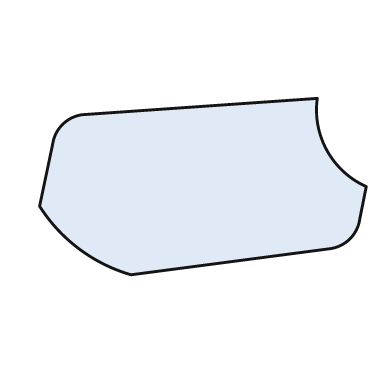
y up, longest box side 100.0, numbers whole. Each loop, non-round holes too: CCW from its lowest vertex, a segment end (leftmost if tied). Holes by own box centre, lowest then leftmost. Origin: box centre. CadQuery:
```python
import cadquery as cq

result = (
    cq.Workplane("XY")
    .moveTo(-22.0, -27.0)
    .lineTo(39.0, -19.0)
    .threePointArc((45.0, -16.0), (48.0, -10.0))
    .lineTo(50.0, 0.0)
    .threePointArc((38.0, 11.0), (35.0, 27.0))
    .lineTo(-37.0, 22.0)
    .threePointArc((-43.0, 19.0), (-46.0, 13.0))
    .lineTo(-50.0, -6.0)
    .threePointArc((-38.0, -19.0), (-22.0, -27.0))
    .close()
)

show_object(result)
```